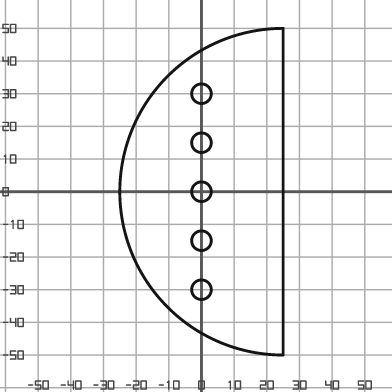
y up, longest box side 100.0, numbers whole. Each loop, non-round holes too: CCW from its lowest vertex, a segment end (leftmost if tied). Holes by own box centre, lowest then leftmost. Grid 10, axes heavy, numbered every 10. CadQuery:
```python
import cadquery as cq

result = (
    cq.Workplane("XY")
    .moveTo(25.0, -50.0)
    .lineTo(25.0, 50.0)
    .threePointArc((-25.0, 0.0), (25.0, -50.0))
    .close()
    .moveTo(0.0, -30.0)
    .circle(3.0)
    .moveTo(0.0, -15.0)
    .circle(3.0)
    .moveTo(0.0, 0.0)
    .circle(3.0)
    .moveTo(0.0, 15.0)
    .circle(3.0)
    .moveTo(0.0, 30.0)
    .circle(3.0)
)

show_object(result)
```